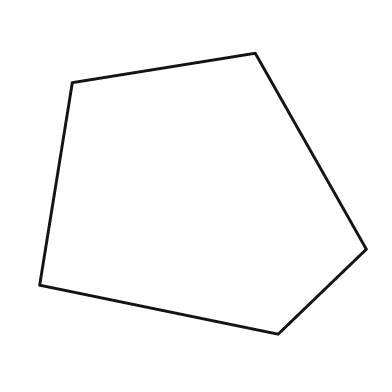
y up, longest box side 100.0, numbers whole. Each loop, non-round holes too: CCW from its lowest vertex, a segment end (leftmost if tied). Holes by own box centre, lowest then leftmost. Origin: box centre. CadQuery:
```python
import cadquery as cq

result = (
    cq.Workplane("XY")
    .moveTo(23.0, -43.0)
    .lineTo(50.0, -17.0)
    .lineTo(16.0, 43.0)
    .lineTo(-40.0, 34.0)
    .lineTo(-50.0, -28.0)
    .close()
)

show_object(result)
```